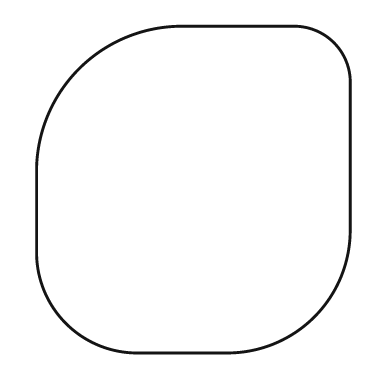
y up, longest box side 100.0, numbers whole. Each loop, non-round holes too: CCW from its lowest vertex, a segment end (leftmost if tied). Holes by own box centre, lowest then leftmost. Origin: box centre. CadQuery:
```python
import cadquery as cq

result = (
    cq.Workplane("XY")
    .moveTo(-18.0, -50.0)
    .lineTo(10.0, -50.0)
    .threePointArc((37.0, -39.0), (48.0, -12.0))
    .lineTo(48.0, 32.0)
    .threePointArc((43.0, 45.0), (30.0, 50.0))
    .lineTo(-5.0, 50.0)
    .threePointArc((-35.0, 37.0), (-48.0, 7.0))
    .lineTo(-48.0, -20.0)
    .threePointArc((-39.0, -41.0), (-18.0, -50.0))
    .close()
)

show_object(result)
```